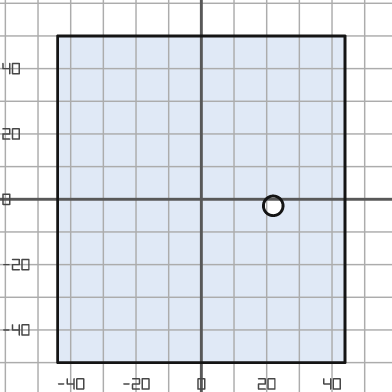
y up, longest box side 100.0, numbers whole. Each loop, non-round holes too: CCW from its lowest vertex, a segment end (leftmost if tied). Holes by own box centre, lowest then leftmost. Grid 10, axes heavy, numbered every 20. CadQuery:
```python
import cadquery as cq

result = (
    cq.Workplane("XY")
    .moveTo(-44.0, -50.0)
    .lineTo(44.0, -50.0)
    .lineTo(44.0, 50.0)
    .lineTo(-44.0, 50.0)
    .close()
    .moveTo(22.0, -2.0)
    .circle(3.0)
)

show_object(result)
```